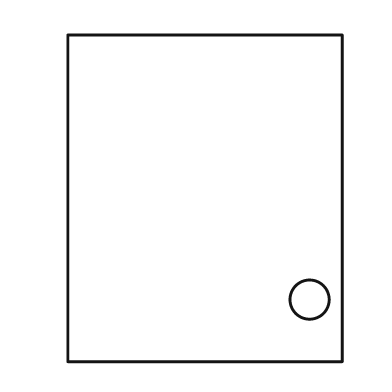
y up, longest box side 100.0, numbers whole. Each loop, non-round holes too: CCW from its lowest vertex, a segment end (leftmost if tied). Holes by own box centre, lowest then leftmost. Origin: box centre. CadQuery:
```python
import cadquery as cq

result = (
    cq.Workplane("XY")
    .moveTo(-42.0, -50.0)
    .lineTo(42.0, -50.0)
    .lineTo(42.0, 50.0)
    .lineTo(-42.0, 50.0)
    .close()
    .moveTo(32.0, -31.0)
    .circle(6.0)
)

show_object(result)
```